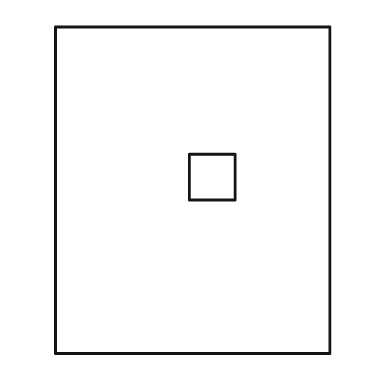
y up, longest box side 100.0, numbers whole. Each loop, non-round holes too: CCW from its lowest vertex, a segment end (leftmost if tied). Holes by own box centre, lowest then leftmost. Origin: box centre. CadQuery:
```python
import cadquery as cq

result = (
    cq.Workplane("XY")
    .moveTo(-42.0, -50.0)
    .lineTo(42.0, -50.0)
    .lineTo(42.0, 50.0)
    .lineTo(-42.0, 50.0)
    .close()
    .moveTo(-1.0, -3.0)
    .lineTo(13.0, -3.0)
    .lineTo(13.0, 11.0)
    .lineTo(-1.0, 11.0)
    .close()
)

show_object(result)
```